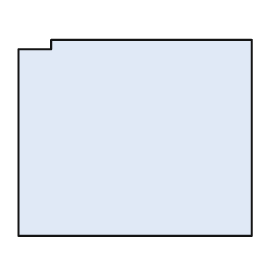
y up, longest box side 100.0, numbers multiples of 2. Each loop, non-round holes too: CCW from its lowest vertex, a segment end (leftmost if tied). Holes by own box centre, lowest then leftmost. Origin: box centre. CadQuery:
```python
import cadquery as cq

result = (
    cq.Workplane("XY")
    .moveTo(-50.0, -42.0)
    .lineTo(50.0, -42.0)
    .lineTo(50.0, 42.0)
    .lineTo(-36.0, 42.0)
    .lineTo(-36.0, 38.0)
    .lineTo(-50.0, 38.0)
    .close()
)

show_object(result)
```